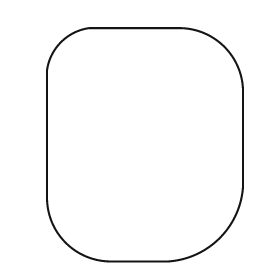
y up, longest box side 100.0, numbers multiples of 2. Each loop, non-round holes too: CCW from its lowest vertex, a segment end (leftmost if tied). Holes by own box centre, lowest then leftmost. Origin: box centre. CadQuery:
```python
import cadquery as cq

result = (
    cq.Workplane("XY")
    .moveTo(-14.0, -50.0)
    .lineTo(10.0, -50.0)
    .threePointArc((32.0, -40.0), (42.0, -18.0))
    .lineTo(42.0, 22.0)
    .threePointArc((34.0, 42.0), (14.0, 50.0))
    .lineTo(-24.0, 50.0)
    .threePointArc((-36.0, 44.0), (-42.0, 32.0))
    .lineTo(-42.0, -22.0)
    .threePointArc((-34.0, -42.0), (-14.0, -50.0))
    .close()
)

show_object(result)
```